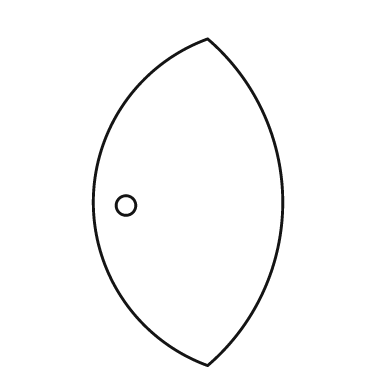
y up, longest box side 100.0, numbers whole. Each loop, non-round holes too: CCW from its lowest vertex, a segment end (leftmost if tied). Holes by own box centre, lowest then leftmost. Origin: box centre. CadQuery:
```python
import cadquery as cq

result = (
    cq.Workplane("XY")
    .moveTo(6.0, -50.0)
    .threePointArc((29.0, 0.0), (6.0, 50.0))
    .threePointArc((-29.0, 0.0), (6.0, -50.0))
    .close()
    .moveTo(-19.0, -1.0)
    .circle(3.0)
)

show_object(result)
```